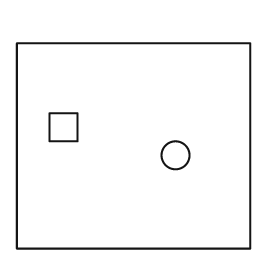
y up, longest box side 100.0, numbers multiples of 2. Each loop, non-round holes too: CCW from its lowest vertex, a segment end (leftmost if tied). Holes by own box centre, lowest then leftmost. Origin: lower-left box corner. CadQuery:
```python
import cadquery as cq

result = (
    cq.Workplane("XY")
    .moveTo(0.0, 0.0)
    .lineTo(100.0, 0.0)
    .lineTo(100.0, 88.0)
    .lineTo(0.0, 88.0)
    .close()
    .moveTo(68.0, 40.0)
    .circle(6.0)
    .moveTo(14.0, 46.0)
    .lineTo(26.0, 46.0)
    .lineTo(26.0, 58.0)
    .lineTo(14.0, 58.0)
    .close()
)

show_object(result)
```